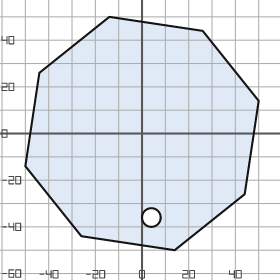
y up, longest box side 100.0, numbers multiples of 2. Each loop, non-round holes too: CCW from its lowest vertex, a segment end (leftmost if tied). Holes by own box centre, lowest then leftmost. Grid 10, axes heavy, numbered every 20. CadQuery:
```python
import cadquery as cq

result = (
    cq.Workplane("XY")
    .moveTo(14.0, -50.0)
    .lineTo(44.0, -26.0)
    .lineTo(50.0, 14.0)
    .lineTo(26.0, 44.0)
    .lineTo(-14.0, 50.0)
    .lineTo(-44.0, 26.0)
    .lineTo(-50.0, -14.0)
    .lineTo(-26.0, -44.0)
    .close()
    .moveTo(4.0, -36.0)
    .circle(4.0)
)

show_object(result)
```